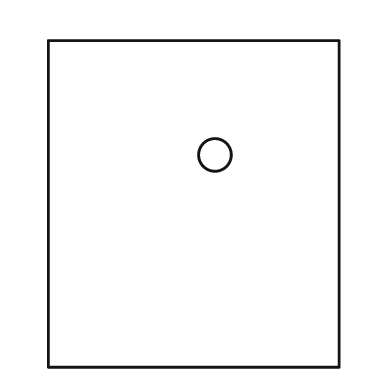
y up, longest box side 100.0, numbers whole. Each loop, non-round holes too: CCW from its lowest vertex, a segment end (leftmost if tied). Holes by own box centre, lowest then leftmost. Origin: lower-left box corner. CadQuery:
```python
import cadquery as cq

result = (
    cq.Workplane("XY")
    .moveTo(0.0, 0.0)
    .lineTo(89.0, 0.0)
    .lineTo(89.0, 100.0)
    .lineTo(0.0, 100.0)
    .close()
    .moveTo(51.0, 65.0)
    .circle(5.0)
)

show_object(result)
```